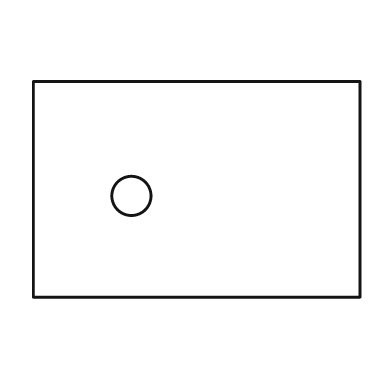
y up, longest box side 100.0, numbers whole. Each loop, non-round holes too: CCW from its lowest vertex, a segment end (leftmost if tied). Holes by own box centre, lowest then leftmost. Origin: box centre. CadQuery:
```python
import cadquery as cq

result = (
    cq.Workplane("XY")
    .moveTo(-50.0, -33.0)
    .lineTo(50.0, -33.0)
    .lineTo(50.0, 33.0)
    .lineTo(-50.0, 33.0)
    .close()
    .moveTo(-20.0, -2.0)
    .circle(6.0)
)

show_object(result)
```